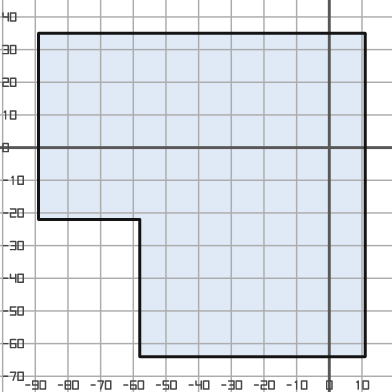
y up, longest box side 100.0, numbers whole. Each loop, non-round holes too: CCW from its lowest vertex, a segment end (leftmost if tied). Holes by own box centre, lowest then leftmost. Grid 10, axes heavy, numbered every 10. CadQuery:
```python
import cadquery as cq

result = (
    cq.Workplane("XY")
    .moveTo(-58.0, -64.0)
    .lineTo(11.0, -64.0)
    .lineTo(11.0, 35.0)
    .lineTo(-89.0, 35.0)
    .lineTo(-89.0, -22.0)
    .lineTo(-58.0, -22.0)
    .close()
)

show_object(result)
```